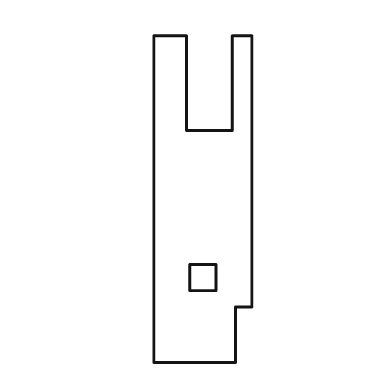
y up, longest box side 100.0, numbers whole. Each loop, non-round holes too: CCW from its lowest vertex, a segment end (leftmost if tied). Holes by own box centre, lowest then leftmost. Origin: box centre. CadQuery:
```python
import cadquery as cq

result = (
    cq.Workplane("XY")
    .moveTo(-15.0, -50.0)
    .lineTo(10.0, -50.0)
    .lineTo(10.0, -33.0)
    .lineTo(15.0, -33.0)
    .lineTo(15.0, 50.0)
    .lineTo(9.0, 50.0)
    .lineTo(9.0, 21.0)
    .lineTo(-5.0, 21.0)
    .lineTo(-5.0, 50.0)
    .lineTo(-15.0, 50.0)
    .close()
    .moveTo(-4.0, -28.0)
    .lineTo(4.0, -28.0)
    .lineTo(4.0, -20.0)
    .lineTo(-4.0, -20.0)
    .close()
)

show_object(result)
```